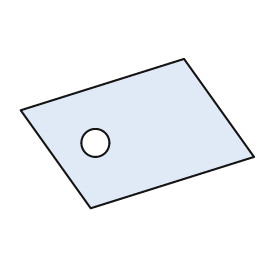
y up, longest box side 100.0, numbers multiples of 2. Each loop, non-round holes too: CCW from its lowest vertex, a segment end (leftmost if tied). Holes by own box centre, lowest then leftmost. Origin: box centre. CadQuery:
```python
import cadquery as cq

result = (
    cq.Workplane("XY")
    .moveTo(-20.0, -32.0)
    .lineTo(50.0, -10.0)
    .lineTo(20.0, 32.0)
    .lineTo(-50.0, 10.0)
    .close()
    .moveTo(-18.0, -4.0)
    .circle(6.0)
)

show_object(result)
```